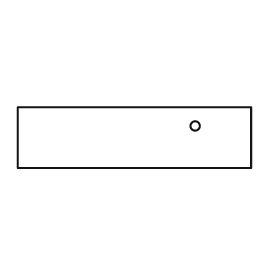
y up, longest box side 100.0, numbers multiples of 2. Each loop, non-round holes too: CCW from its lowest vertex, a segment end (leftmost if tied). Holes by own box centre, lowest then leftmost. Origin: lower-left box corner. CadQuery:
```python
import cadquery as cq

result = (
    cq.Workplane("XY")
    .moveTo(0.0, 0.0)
    .lineTo(100.0, 0.0)
    .lineTo(100.0, 26.0)
    .lineTo(0.0, 26.0)
    .close()
    .moveTo(76.0, 18.0)
    .circle(2.0)
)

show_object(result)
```